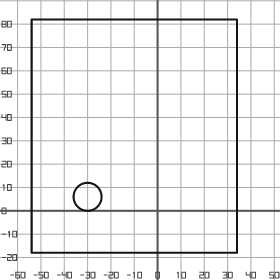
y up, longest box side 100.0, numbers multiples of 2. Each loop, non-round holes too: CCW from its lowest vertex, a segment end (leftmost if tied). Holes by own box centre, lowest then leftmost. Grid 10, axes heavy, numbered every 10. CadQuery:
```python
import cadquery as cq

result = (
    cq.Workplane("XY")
    .moveTo(-54.0, -18.0)
    .lineTo(34.0, -18.0)
    .lineTo(34.0, 82.0)
    .lineTo(-54.0, 82.0)
    .close()
    .moveTo(-30.0, 6.0)
    .circle(6.0)
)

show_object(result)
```